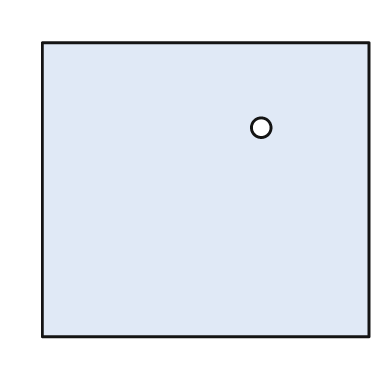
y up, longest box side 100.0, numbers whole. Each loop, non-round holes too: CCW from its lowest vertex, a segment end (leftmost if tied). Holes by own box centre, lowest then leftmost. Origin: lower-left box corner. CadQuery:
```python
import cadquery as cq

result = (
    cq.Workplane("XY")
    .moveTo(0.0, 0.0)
    .lineTo(100.0, 0.0)
    .lineTo(100.0, 90.0)
    .lineTo(0.0, 90.0)
    .close()
    .moveTo(67.0, 64.0)
    .circle(3.0)
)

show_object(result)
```